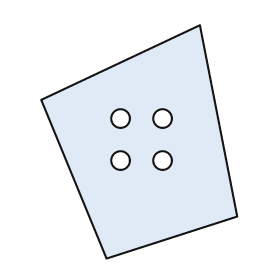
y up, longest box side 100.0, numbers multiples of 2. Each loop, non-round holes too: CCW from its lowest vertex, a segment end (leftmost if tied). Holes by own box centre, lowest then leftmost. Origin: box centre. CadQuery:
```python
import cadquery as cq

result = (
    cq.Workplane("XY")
    .moveTo(-14.0, -50.0)
    .lineTo(42.0, -32.0)
    .lineTo(26.0, 50.0)
    .lineTo(-42.0, 18.0)
    .close()
    .moveTo(-8.0, -8.0)
    .circle(4.0)
    .moveTo(10.0, -8.0)
    .circle(4.0)
    .moveTo(-8.0, 10.0)
    .circle(4.0)
    .moveTo(10.0, 10.0)
    .circle(4.0)
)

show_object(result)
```